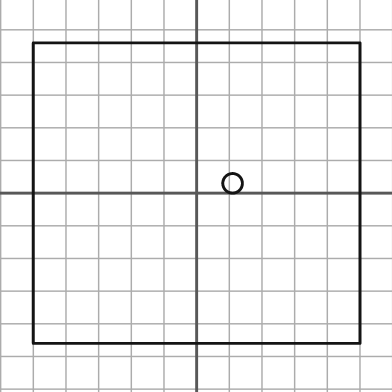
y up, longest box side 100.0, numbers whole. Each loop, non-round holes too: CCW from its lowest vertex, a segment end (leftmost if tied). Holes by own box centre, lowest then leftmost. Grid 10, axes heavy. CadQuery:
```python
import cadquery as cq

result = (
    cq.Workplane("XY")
    .moveTo(-50.0, -46.0)
    .lineTo(50.0, -46.0)
    .lineTo(50.0, 46.0)
    .lineTo(-50.0, 46.0)
    .close()
    .moveTo(11.0, 3.0)
    .circle(3.0)
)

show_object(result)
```